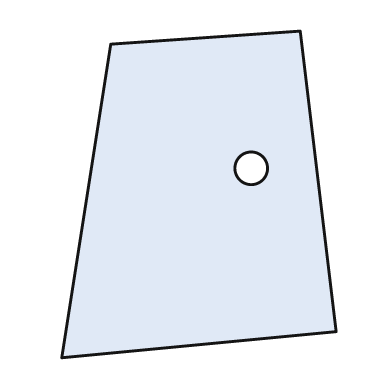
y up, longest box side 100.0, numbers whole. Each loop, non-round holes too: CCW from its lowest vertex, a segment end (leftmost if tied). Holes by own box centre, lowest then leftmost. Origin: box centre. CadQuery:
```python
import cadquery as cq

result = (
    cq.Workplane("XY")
    .moveTo(-42.0, -50.0)
    .lineTo(42.0, -42.0)
    .lineTo(31.0, 50.0)
    .lineTo(-27.0, 46.0)
    .close()
    .moveTo(16.0, 8.0)
    .circle(5.0)
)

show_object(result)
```